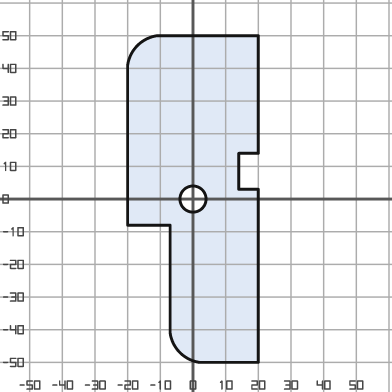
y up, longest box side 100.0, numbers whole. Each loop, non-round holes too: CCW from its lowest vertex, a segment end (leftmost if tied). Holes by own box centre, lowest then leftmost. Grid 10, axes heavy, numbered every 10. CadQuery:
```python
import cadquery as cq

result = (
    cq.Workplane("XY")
    .moveTo(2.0, -50.0)
    .lineTo(20.0, -50.0)
    .lineTo(20.0, 3.0)
    .lineTo(14.0, 3.0)
    .lineTo(14.0, 14.0)
    .lineTo(20.0, 14.0)
    .lineTo(20.0, 50.0)
    .lineTo(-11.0, 50.0)
    .threePointArc((-17.0, 47.0), (-20.0, 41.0))
    .lineTo(-20.0, -8.0)
    .lineTo(-7.0, -8.0)
    .lineTo(-7.0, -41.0)
    .threePointArc((-4.0, -47.0), (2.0, -50.0))
    .close()
    .moveTo(0.0, 0.0)
    .circle(4.0)
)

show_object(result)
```